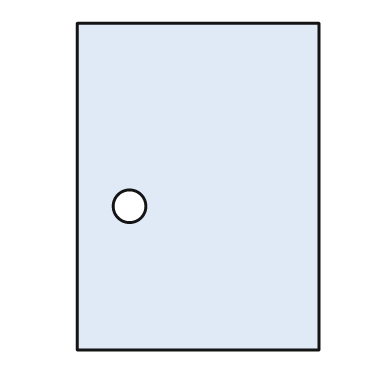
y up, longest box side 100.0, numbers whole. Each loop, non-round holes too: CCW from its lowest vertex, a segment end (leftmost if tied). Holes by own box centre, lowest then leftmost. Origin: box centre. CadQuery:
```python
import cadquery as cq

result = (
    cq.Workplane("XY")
    .moveTo(-37.0, -50.0)
    .lineTo(37.0, -50.0)
    .lineTo(37.0, 50.0)
    .lineTo(-37.0, 50.0)
    .close()
    .moveTo(-21.0, -6.0)
    .circle(5.0)
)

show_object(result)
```